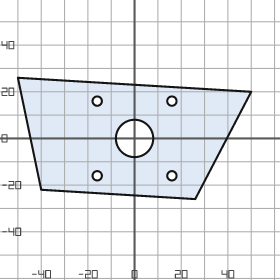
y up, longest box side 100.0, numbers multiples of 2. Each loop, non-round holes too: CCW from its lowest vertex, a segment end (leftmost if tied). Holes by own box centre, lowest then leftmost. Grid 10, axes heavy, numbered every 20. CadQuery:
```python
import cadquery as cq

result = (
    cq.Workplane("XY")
    .moveTo(26.0, -26.0)
    .lineTo(50.0, 20.0)
    .lineTo(-50.0, 26.0)
    .lineTo(-40.0, -22.0)
    .close()
    .moveTo(-16.0, -16.0)
    .circle(2.0)
    .moveTo(16.0, -16.0)
    .circle(2.0)
    .moveTo(0.0, 0.0)
    .circle(8.0)
    .moveTo(-16.0, 16.0)
    .circle(2.0)
    .moveTo(16.0, 16.0)
    .circle(2.0)
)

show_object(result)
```